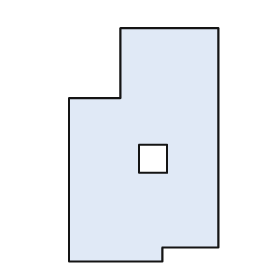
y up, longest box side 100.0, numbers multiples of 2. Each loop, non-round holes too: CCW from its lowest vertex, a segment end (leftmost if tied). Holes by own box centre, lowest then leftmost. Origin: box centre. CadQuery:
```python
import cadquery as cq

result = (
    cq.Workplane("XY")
    .moveTo(-32.0, -50.0)
    .lineTo(8.0, -50.0)
    .lineTo(8.0, -44.0)
    .lineTo(32.0, -44.0)
    .lineTo(32.0, 50.0)
    .lineTo(-10.0, 50.0)
    .lineTo(-10.0, 20.0)
    .lineTo(-32.0, 20.0)
    .close()
    .moveTo(-2.0, -12.0)
    .lineTo(10.0, -12.0)
    .lineTo(10.0, 0.0)
    .lineTo(-2.0, 0.0)
    .close()
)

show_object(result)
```